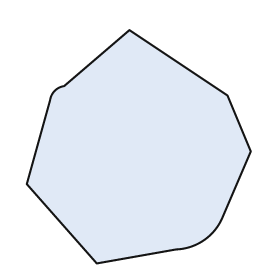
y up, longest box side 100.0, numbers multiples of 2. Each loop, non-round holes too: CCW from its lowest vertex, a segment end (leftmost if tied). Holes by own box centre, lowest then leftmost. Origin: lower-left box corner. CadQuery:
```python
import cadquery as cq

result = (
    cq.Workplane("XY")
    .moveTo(30.0, 0.0)
    .lineTo(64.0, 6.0)
    .threePointArc((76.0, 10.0), (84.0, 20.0))
    .lineTo(96.0, 48.0)
    .lineTo(86.0, 72.0)
    .lineTo(44.0, 100.0)
    .lineTo(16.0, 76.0)
    .threePointArc((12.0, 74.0), (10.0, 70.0))
    .lineTo(0.0, 34.0)
    .close()
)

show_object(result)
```